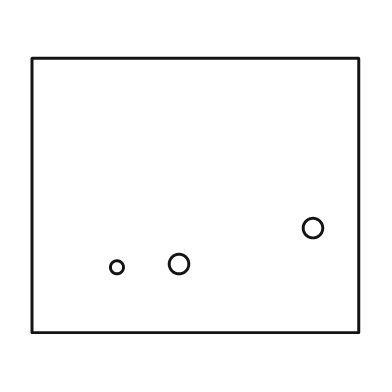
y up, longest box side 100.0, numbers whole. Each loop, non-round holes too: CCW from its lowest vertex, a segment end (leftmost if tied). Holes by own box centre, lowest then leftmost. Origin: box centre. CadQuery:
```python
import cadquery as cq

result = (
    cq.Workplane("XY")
    .moveTo(-50.0, -42.0)
    .lineTo(50.0, -42.0)
    .lineTo(50.0, 42.0)
    .lineTo(-50.0, 42.0)
    .close()
    .moveTo(-24.0, -22.0)
    .circle(2.0)
    .moveTo(-5.0, -21.0)
    .circle(3.0)
    .moveTo(36.0, -10.0)
    .circle(3.0)
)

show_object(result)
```